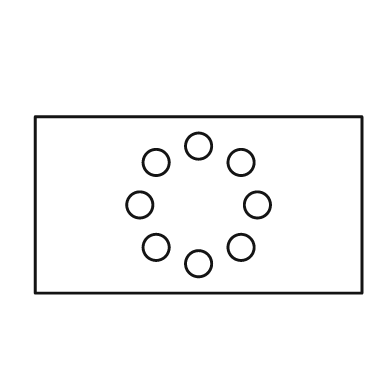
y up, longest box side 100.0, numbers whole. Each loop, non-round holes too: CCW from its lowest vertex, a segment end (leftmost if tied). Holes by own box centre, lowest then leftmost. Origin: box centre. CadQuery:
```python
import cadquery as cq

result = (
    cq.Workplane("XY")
    .moveTo(-50.0, -27.0)
    .lineTo(50.0, -27.0)
    .lineTo(50.0, 27.0)
    .lineTo(-50.0, 27.0)
    .close()
    .moveTo(0.0, -18.0)
    .circle(4.0)
    .moveTo(-13.0, -13.0)
    .circle(4.0)
    .moveTo(13.0, -13.0)
    .circle(4.0)
    .moveTo(-18.0, 0.0)
    .circle(4.0)
    .moveTo(18.0, 0.0)
    .circle(4.0)
    .moveTo(-13.0, 13.0)
    .circle(4.0)
    .moveTo(13.0, 13.0)
    .circle(4.0)
    .moveTo(0.0, 18.0)
    .circle(4.0)
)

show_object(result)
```